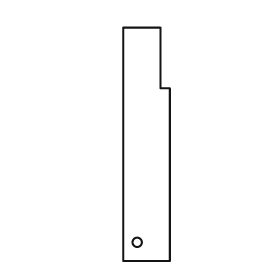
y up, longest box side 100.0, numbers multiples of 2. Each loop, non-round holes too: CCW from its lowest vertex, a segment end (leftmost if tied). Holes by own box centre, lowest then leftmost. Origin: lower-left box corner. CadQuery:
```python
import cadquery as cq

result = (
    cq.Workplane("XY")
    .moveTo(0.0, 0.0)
    .lineTo(20.0, 0.0)
    .lineTo(20.0, 74.0)
    .lineTo(16.0, 74.0)
    .lineTo(16.0, 100.0)
    .lineTo(0.0, 100.0)
    .close()
    .moveTo(6.0, 8.0)
    .circle(2.0)
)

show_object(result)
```